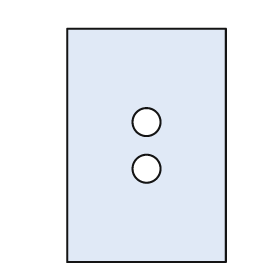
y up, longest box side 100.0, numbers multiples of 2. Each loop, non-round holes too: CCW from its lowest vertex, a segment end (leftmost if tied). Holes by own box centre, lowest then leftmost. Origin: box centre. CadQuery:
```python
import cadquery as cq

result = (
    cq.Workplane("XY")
    .moveTo(-34.0, -50.0)
    .lineTo(34.0, -50.0)
    .lineTo(34.0, 50.0)
    .lineTo(-34.0, 50.0)
    .close()
    .moveTo(0.0, -10.0)
    .circle(6.0)
    .moveTo(0.0, 10.0)
    .circle(6.0)
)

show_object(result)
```